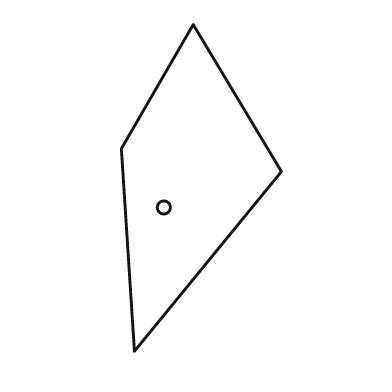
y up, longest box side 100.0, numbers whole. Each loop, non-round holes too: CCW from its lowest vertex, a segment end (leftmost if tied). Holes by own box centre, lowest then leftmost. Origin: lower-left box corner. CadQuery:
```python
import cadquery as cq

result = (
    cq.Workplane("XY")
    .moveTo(4.0, 0.0)
    .lineTo(49.0, 55.0)
    .lineTo(22.0, 100.0)
    .lineTo(0.0, 62.0)
    .close()
    .moveTo(13.0, 44.0)
    .circle(2.0)
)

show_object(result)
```